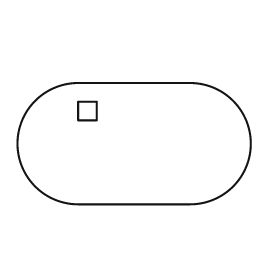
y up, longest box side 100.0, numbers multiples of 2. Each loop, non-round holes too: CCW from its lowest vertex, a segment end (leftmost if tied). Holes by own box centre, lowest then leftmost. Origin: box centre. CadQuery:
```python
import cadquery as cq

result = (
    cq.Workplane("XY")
    .moveTo(-24.0, -26.0)
    .lineTo(24.0, -26.0)
    .threePointArc((50.0, 0.0), (24.0, 26.0))
    .lineTo(-24.0, 26.0)
    .threePointArc((-50.0, 0.0), (-24.0, -26.0))
    .close()
    .moveTo(-24.0, 10.0)
    .lineTo(-16.0, 10.0)
    .lineTo(-16.0, 18.0)
    .lineTo(-24.0, 18.0)
    .close()
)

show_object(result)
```